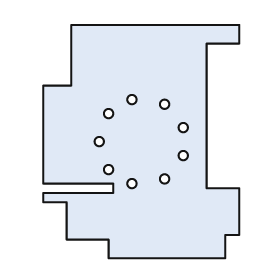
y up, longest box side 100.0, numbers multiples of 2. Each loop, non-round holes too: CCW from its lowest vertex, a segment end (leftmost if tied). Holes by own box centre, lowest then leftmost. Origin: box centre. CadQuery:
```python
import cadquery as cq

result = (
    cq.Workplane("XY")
    .moveTo(-14.0, -50.0)
    .lineTo(36.0, -50.0)
    .lineTo(36.0, -40.0)
    .lineTo(42.0, -40.0)
    .lineTo(42.0, -20.0)
    .lineTo(28.0, -20.0)
    .lineTo(28.0, 42.0)
    .lineTo(42.0, 42.0)
    .lineTo(42.0, 50.0)
    .lineTo(-30.0, 50.0)
    .lineTo(-30.0, 24.0)
    .lineTo(-42.0, 24.0)
    .lineTo(-42.0, -18.0)
    .lineTo(-12.0, -18.0)
    .lineTo(-12.0, -22.0)
    .lineTo(-42.0, -22.0)
    .lineTo(-42.0, -26.0)
    .lineTo(-32.0, -26.0)
    .lineTo(-32.0, -42.0)
    .lineTo(-14.0, -42.0)
    .close()
    .moveTo(-4.0, -18.0)
    .circle(2.0)
    .moveTo(10.0, -16.0)
    .circle(2.0)
    .moveTo(-14.0, -12.0)
    .circle(2.0)
    .moveTo(18.0, -6.0)
    .circle(2.0)
    .moveTo(-18.0, 0.0)
    .circle(2.0)
    .moveTo(18.0, 6.0)
    .circle(2.0)
    .moveTo(-14.0, 12.0)
    .circle(2.0)
    .moveTo(10.0, 16.0)
    .circle(2.0)
    .moveTo(-4.0, 18.0)
    .circle(2.0)
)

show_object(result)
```